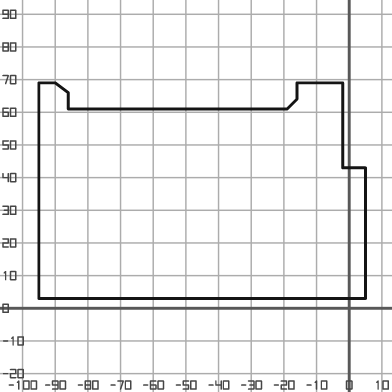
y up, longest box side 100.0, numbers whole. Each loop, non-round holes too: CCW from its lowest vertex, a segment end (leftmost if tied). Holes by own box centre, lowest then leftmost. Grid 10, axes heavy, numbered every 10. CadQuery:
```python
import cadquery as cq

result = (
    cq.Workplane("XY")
    .moveTo(-95.0, 3.0)
    .lineTo(5.0, 3.0)
    .lineTo(5.0, 43.0)
    .lineTo(-2.0, 43.0)
    .lineTo(-2.0, 69.0)
    .lineTo(-16.0, 69.0)
    .lineTo(-16.0, 64.0)
    .lineTo(-19.0, 61.0)
    .lineTo(-86.0, 61.0)
    .lineTo(-86.0, 66.0)
    .lineTo(-90.0, 69.0)
    .lineTo(-95.0, 69.0)
    .close()
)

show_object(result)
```